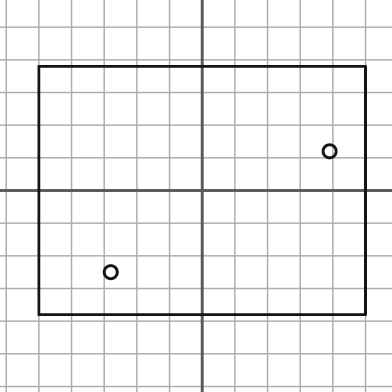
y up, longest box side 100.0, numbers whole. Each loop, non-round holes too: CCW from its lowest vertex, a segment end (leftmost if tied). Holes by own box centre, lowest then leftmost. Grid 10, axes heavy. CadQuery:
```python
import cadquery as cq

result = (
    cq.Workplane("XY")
    .moveTo(-50.0, -38.0)
    .lineTo(50.0, -38.0)
    .lineTo(50.0, 38.0)
    .lineTo(-50.0, 38.0)
    .close()
    .moveTo(-28.0, -25.0)
    .circle(2.0)
    .moveTo(39.0, 12.0)
    .circle(2.0)
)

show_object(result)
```